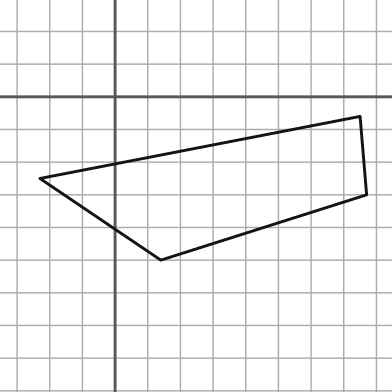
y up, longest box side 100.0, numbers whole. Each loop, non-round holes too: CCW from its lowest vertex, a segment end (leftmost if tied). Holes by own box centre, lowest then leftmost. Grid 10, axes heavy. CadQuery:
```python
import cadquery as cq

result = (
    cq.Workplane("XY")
    .moveTo(14.0, -50.0)
    .lineTo(77.0, -30.0)
    .lineTo(75.0, -6.0)
    .lineTo(-23.0, -25.0)
    .close()
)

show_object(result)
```